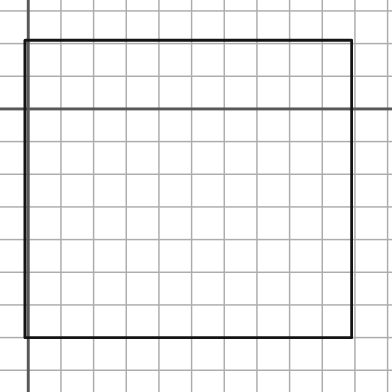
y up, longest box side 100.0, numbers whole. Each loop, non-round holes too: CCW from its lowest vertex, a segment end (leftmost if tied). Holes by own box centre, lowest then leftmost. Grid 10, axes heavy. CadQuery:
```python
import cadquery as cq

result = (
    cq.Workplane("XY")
    .moveTo(-1.0, -70.0)
    .lineTo(99.0, -70.0)
    .lineTo(99.0, 21.0)
    .lineTo(-1.0, 21.0)
    .close()
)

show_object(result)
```